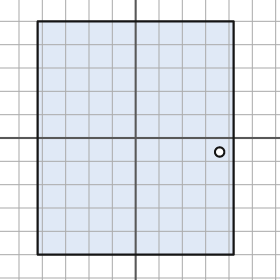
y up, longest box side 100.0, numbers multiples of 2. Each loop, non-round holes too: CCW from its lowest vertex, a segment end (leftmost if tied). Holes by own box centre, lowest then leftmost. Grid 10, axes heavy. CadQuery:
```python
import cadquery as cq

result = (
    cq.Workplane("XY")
    .moveTo(-42.0, -50.0)
    .lineTo(42.0, -50.0)
    .lineTo(42.0, 50.0)
    .lineTo(-42.0, 50.0)
    .close()
    .moveTo(36.0, -6.0)
    .circle(2.0)
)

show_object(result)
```